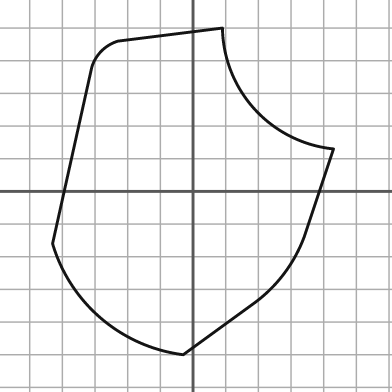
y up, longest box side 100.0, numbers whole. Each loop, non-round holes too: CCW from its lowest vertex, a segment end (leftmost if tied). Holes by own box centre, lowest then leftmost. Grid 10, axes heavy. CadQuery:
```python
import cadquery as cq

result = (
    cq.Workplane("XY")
    .moveTo(-3.0, -50.0)
    .lineTo(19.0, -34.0)
    .threePointArc((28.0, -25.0), (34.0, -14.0))
    .lineTo(43.0, 13.0)
    .threePointArc((19.0, 25.0), (9.0, 50.0))
    .lineTo(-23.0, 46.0)
    .threePointArc((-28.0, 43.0), (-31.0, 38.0))
    .lineTo(-43.0, -16.0)
    .threePointArc((-28.0, -39.0), (-3.0, -50.0))
    .close()
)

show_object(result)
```